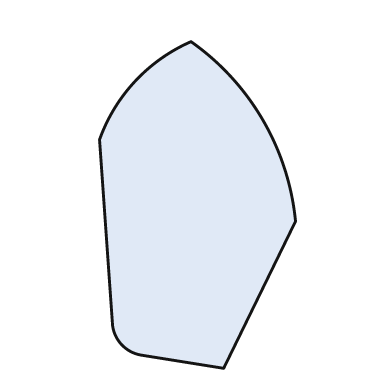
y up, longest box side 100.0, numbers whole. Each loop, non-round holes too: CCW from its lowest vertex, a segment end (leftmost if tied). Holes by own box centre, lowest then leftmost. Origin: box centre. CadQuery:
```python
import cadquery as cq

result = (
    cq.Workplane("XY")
    .moveTo(8.0, -50.0)
    .lineTo(30.0, -5.0)
    .threePointArc((20.0, 26.0), (-2.0, 50.0))
    .threePointArc((-19.0, 38.0), (-30.0, 20.0))
    .lineTo(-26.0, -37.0)
    .threePointArc((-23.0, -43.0), (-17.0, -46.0))
    .close()
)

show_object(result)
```